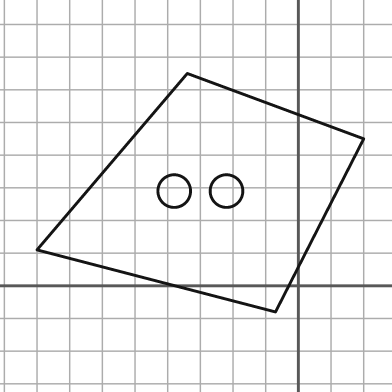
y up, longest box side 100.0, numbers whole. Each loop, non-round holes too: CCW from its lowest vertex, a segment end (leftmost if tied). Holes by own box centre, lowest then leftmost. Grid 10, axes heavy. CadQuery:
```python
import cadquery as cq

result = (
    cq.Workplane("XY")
    .moveTo(-7.0, -8.0)
    .lineTo(20.0, 45.0)
    .lineTo(-34.0, 65.0)
    .lineTo(-80.0, 11.0)
    .close()
    .moveTo(-38.0, 29.0)
    .circle(5.0)
    .moveTo(-22.0, 29.0)
    .circle(5.0)
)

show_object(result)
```